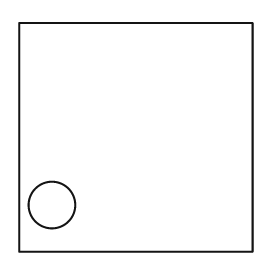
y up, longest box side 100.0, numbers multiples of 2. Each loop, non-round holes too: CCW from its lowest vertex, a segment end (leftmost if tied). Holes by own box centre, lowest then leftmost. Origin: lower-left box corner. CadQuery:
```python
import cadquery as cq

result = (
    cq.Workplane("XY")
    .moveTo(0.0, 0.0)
    .lineTo(100.0, 0.0)
    .lineTo(100.0, 98.0)
    .lineTo(0.0, 98.0)
    .close()
    .moveTo(14.0, 20.0)
    .circle(10.0)
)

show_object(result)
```